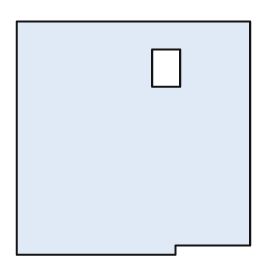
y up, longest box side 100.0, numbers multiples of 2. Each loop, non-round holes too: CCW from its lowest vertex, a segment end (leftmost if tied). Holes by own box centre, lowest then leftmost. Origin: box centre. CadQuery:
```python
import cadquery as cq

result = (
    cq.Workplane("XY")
    .moveTo(-50.0, -50.0)
    .lineTo(18.0, -50.0)
    .lineTo(18.0, -46.0)
    .lineTo(50.0, -46.0)
    .lineTo(50.0, 50.0)
    .lineTo(-50.0, 50.0)
    .close()
    .moveTo(8.0, 22.0)
    .lineTo(20.0, 22.0)
    .lineTo(20.0, 38.0)
    .lineTo(8.0, 38.0)
    .close()
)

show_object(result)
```